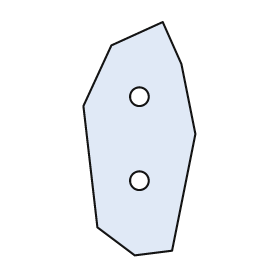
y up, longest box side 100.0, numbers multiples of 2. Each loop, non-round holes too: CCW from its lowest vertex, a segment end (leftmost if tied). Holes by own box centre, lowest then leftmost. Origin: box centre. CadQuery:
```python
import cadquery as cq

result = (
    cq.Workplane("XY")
    .moveTo(-2.0, -50.0)
    .lineTo(14.0, -48.0)
    .lineTo(24.0, 2.0)
    .lineTo(18.0, 32.0)
    .lineTo(10.0, 50.0)
    .lineTo(-12.0, 40.0)
    .lineTo(-24.0, 14.0)
    .lineTo(-18.0, -38.0)
    .close()
    .moveTo(0.0, -18.0)
    .circle(4.0)
    .moveTo(0.0, 18.0)
    .circle(4.0)
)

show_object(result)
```